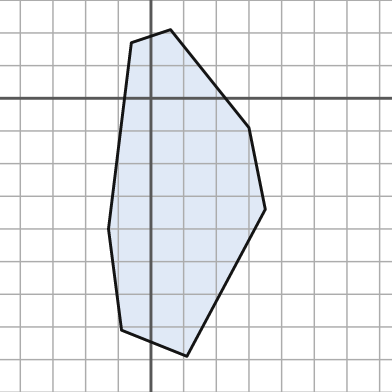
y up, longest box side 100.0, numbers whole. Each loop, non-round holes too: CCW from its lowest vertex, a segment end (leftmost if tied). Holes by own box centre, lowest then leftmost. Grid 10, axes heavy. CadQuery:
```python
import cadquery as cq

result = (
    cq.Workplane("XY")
    .moveTo(11.0, -79.0)
    .lineTo(35.0, -34.0)
    .lineTo(30.0, -9.0)
    .lineTo(6.0, 21.0)
    .lineTo(-6.0, 17.0)
    .lineTo(-13.0, -40.0)
    .lineTo(-9.0, -71.0)
    .close()
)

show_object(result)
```